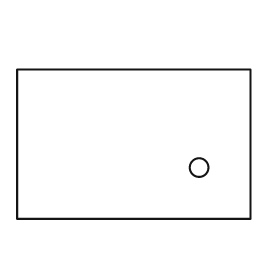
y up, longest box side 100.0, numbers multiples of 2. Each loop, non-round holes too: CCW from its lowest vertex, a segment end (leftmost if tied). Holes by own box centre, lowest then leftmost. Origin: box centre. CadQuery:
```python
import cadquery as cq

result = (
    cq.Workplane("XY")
    .moveTo(-50.0, -32.0)
    .lineTo(50.0, -32.0)
    .lineTo(50.0, 32.0)
    .lineTo(-50.0, 32.0)
    .close()
    .moveTo(28.0, -10.0)
    .circle(4.0)
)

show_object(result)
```